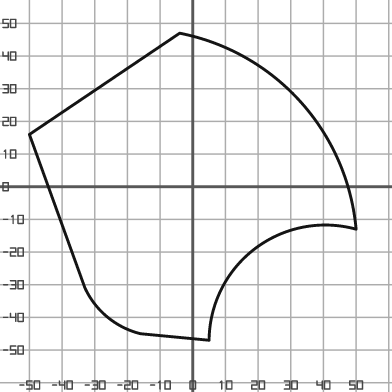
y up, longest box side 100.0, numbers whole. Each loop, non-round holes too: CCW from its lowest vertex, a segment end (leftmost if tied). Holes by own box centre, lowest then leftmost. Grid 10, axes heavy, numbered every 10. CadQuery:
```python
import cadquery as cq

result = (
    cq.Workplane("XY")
    .moveTo(5.0, -47.0)
    .threePointArc((19.0, -19.0), (50.0, -13.0))
    .threePointArc((33.0, 26.0), (-4.0, 47.0))
    .lineTo(-50.0, 16.0)
    .lineTo(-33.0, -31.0)
    .threePointArc((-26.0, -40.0), (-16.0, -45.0))
    .close()
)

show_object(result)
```